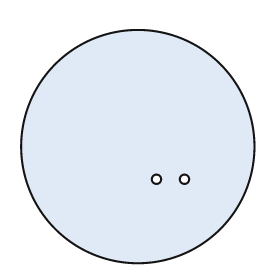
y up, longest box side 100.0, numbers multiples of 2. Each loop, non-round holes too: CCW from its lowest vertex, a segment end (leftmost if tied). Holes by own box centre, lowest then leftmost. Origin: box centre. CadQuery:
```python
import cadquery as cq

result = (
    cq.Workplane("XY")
    .moveTo(0.0, 0.0)
    .circle(50.0)
    .moveTo(8.0, -14.0)
    .circle(2.0)
    .moveTo(20.0, -14.0)
    .circle(2.0)
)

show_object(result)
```